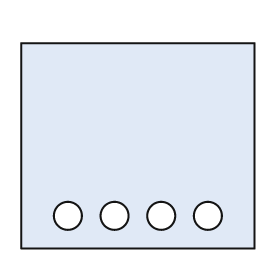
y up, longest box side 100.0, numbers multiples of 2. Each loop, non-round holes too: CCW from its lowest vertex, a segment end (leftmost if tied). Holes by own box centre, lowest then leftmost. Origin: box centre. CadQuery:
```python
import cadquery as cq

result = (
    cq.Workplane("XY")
    .moveTo(-50.0, -44.0)
    .lineTo(50.0, -44.0)
    .lineTo(50.0, 44.0)
    .lineTo(-50.0, 44.0)
    .close()
    .moveTo(-30.0, -30.0)
    .circle(6.0)
    .moveTo(-10.0, -30.0)
    .circle(6.0)
    .moveTo(10.0, -30.0)
    .circle(6.0)
    .moveTo(30.0, -30.0)
    .circle(6.0)
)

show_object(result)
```